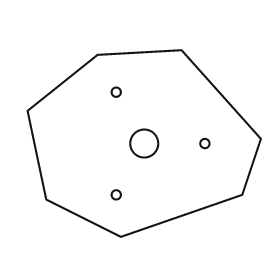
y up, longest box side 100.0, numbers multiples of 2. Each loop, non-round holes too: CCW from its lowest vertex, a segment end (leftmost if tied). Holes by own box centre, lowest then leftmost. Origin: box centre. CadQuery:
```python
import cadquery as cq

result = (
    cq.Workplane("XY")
    .moveTo(-10.0, -40.0)
    .lineTo(42.0, -22.0)
    .lineTo(50.0, 2.0)
    .lineTo(16.0, 40.0)
    .lineTo(-20.0, 38.0)
    .lineTo(-50.0, 14.0)
    .lineTo(-42.0, -24.0)
    .close()
    .moveTo(-12.0, -22.0)
    .circle(2.0)
    .moveTo(0.0, 0.0)
    .circle(6.0)
    .moveTo(26.0, 0.0)
    .circle(2.0)
    .moveTo(-12.0, 22.0)
    .circle(2.0)
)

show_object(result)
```